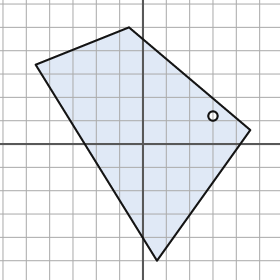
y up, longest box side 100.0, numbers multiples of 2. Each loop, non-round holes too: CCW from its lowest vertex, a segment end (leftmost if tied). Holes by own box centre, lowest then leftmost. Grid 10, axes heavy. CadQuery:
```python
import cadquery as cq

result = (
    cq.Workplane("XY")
    .moveTo(6.0, -50.0)
    .lineTo(46.0, 6.0)
    .lineTo(-6.0, 50.0)
    .lineTo(-46.0, 34.0)
    .close()
    .moveTo(30.0, 12.0)
    .circle(2.0)
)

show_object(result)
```